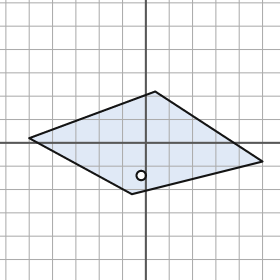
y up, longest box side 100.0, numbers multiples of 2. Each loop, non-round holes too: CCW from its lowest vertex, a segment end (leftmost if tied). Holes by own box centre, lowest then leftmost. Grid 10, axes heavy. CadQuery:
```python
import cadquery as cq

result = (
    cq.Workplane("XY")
    .moveTo(-6.0, -22.0)
    .lineTo(50.0, -8.0)
    .lineTo(4.0, 22.0)
    .lineTo(-50.0, 2.0)
    .close()
    .moveTo(-2.0, -14.0)
    .circle(2.0)
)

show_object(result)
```